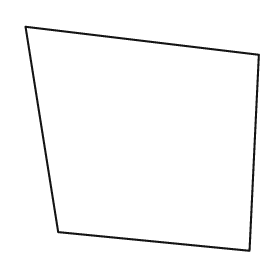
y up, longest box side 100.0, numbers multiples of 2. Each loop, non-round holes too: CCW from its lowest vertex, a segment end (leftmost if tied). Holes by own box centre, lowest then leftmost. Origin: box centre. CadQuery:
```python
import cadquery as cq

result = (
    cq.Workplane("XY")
    .moveTo(46.0, -48.0)
    .lineTo(50.0, 36.0)
    .lineTo(-50.0, 48.0)
    .lineTo(-36.0, -40.0)
    .close()
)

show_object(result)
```